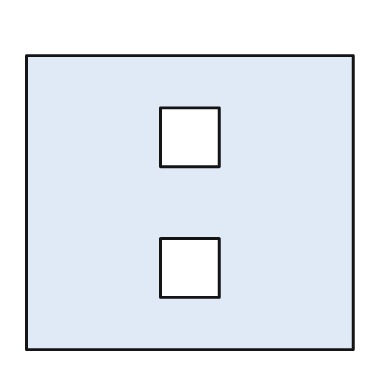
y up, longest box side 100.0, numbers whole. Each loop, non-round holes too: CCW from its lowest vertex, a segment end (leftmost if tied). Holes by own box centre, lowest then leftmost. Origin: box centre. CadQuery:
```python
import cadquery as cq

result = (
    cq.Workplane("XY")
    .moveTo(-50.0, -45.0)
    .lineTo(50.0, -45.0)
    .lineTo(50.0, 45.0)
    .lineTo(-50.0, 45.0)
    .close()
    .moveTo(-9.0, -29.0)
    .lineTo(9.0, -29.0)
    .lineTo(9.0, -11.0)
    .lineTo(-9.0, -11.0)
    .close()
    .moveTo(-9.0, 11.0)
    .lineTo(9.0, 11.0)
    .lineTo(9.0, 29.0)
    .lineTo(-9.0, 29.0)
    .close()
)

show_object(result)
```